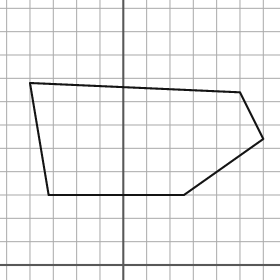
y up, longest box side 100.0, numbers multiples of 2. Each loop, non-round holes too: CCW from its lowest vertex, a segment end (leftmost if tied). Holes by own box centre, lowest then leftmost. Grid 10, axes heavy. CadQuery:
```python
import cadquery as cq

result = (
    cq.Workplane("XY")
    .moveTo(-32.0, 30.0)
    .lineTo(26.0, 30.0)
    .lineTo(60.0, 54.0)
    .lineTo(50.0, 74.0)
    .lineTo(-40.0, 78.0)
    .close()
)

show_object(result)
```